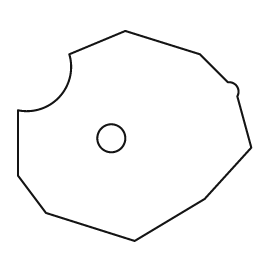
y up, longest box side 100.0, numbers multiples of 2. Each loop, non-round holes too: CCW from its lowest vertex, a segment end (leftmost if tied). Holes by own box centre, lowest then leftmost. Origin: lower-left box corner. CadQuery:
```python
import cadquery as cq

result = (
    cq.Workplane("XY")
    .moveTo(50.0, 0.0)
    .lineTo(80.0, 18.0)
    .lineTo(100.0, 40.0)
    .lineTo(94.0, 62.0)
    .threePointArc((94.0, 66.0), (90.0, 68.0))
    .lineTo(78.0, 80.0)
    .lineTo(46.0, 90.0)
    .lineTo(22.0, 80.0)
    .threePointArc((18.0, 62.0), (0.0, 56.0))
    .lineTo(0.0, 28.0)
    .lineTo(12.0, 12.0)
    .close()
    .moveTo(40.0, 44.0)
    .circle(6.0)
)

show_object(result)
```